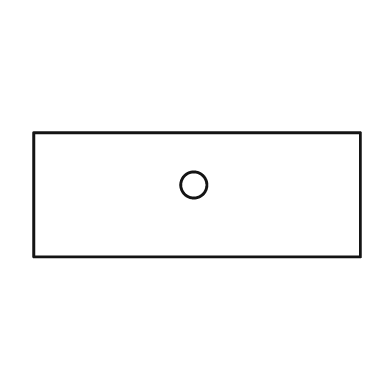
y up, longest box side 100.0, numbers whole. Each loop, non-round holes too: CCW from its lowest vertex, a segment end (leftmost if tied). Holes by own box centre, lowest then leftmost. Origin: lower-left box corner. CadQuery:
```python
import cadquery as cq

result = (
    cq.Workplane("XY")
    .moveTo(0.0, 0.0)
    .lineTo(100.0, 0.0)
    .lineTo(100.0, 38.0)
    .lineTo(0.0, 38.0)
    .close()
    .moveTo(49.0, 22.0)
    .circle(4.0)
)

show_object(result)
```